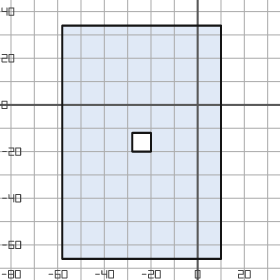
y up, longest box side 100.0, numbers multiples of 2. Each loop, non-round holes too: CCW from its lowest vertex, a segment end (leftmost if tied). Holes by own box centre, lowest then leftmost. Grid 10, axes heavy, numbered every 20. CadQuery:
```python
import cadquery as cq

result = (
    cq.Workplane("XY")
    .moveTo(-58.0, -66.0)
    .lineTo(10.0, -66.0)
    .lineTo(10.0, 34.0)
    .lineTo(-58.0, 34.0)
    .close()
    .moveTo(-28.0, -20.0)
    .lineTo(-20.0, -20.0)
    .lineTo(-20.0, -12.0)
    .lineTo(-28.0, -12.0)
    .close()
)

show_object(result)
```